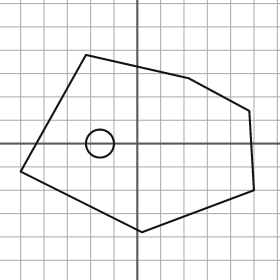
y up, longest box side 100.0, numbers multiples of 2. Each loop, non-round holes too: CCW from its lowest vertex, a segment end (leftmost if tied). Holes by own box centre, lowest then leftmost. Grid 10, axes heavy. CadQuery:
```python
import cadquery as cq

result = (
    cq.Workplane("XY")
    .moveTo(2.0, -38.0)
    .lineTo(50.0, -20.0)
    .lineTo(48.0, 14.0)
    .lineTo(22.0, 28.0)
    .lineTo(-22.0, 38.0)
    .lineTo(-50.0, -12.0)
    .close()
    .moveTo(-16.0, 0.0)
    .circle(6.0)
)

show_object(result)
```